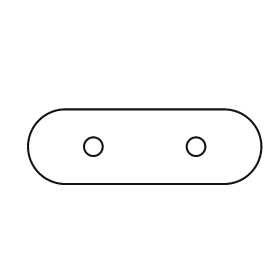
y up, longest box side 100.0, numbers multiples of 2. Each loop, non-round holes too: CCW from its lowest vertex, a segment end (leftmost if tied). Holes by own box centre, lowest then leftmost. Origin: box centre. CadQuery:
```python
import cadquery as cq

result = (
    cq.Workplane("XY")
    .moveTo(-34.0, -16.0)
    .lineTo(34.0, -16.0)
    .threePointArc((50.0, 0.0), (34.0, 16.0))
    .lineTo(-34.0, 16.0)
    .threePointArc((-50.0, 0.0), (-34.0, -16.0))
    .close()
    .moveTo(-22.0, 0.0)
    .circle(4.0)
    .moveTo(22.0, 0.0)
    .circle(4.0)
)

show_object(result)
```